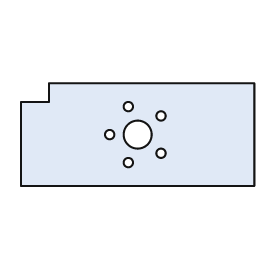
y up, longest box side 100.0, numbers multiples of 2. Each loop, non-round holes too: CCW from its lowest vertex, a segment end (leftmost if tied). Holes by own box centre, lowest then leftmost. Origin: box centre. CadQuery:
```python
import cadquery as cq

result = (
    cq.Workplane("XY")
    .moveTo(-50.0, -22.0)
    .lineTo(50.0, -22.0)
    .lineTo(50.0, 22.0)
    .lineTo(-38.0, 22.0)
    .lineTo(-38.0, 14.0)
    .lineTo(-50.0, 14.0)
    .close()
    .moveTo(-4.0, -12.0)
    .circle(2.0)
    .moveTo(10.0, -8.0)
    .circle(2.0)
    .moveTo(-12.0, 0.0)
    .circle(2.0)
    .moveTo(0.0, 0.0)
    .circle(6.0)
    .moveTo(10.0, 8.0)
    .circle(2.0)
    .moveTo(-4.0, 12.0)
    .circle(2.0)
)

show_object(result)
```